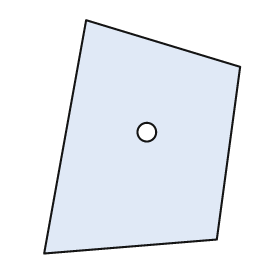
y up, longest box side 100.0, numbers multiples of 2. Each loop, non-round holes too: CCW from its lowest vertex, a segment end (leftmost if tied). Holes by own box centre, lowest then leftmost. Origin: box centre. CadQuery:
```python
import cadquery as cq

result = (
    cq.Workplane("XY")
    .moveTo(-42.0, -50.0)
    .lineTo(32.0, -44.0)
    .lineTo(42.0, 30.0)
    .lineTo(-24.0, 50.0)
    .close()
    .moveTo(2.0, 2.0)
    .circle(4.0)
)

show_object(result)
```